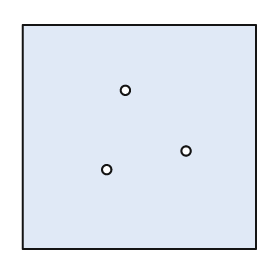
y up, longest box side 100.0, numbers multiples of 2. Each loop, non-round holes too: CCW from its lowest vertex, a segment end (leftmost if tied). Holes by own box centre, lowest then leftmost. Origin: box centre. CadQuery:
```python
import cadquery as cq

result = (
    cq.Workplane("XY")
    .moveTo(-50.0, -48.0)
    .lineTo(50.0, -48.0)
    .lineTo(50.0, 48.0)
    .lineTo(-50.0, 48.0)
    .close()
    .moveTo(-14.0, -14.0)
    .circle(2.0)
    .moveTo(20.0, -6.0)
    .circle(2.0)
    .moveTo(-6.0, 20.0)
    .circle(2.0)
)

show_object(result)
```